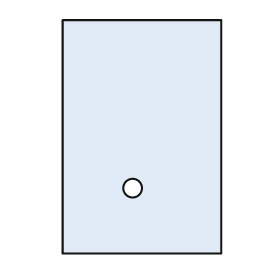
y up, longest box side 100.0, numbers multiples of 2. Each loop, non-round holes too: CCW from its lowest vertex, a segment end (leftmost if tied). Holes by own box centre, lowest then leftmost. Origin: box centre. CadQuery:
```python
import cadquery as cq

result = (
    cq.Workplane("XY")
    .moveTo(-34.0, -50.0)
    .lineTo(34.0, -50.0)
    .lineTo(34.0, 50.0)
    .lineTo(-34.0, 50.0)
    .close()
    .moveTo(-4.0, -22.0)
    .circle(4.0)
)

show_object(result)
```